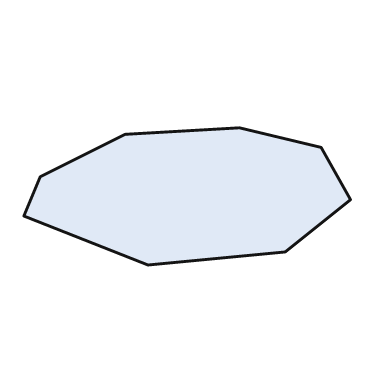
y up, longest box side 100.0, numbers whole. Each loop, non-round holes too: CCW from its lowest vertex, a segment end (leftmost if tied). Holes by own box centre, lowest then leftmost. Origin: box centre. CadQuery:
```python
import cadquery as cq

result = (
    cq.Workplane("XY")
    .moveTo(-12.0, -21.0)
    .lineTo(30.0, -17.0)
    .lineTo(50.0, -1.0)
    .lineTo(41.0, 15.0)
    .lineTo(16.0, 21.0)
    .lineTo(-19.0, 19.0)
    .lineTo(-45.0, 6.0)
    .lineTo(-50.0, -6.0)
    .close()
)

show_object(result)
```